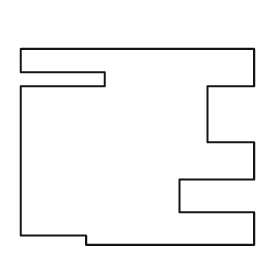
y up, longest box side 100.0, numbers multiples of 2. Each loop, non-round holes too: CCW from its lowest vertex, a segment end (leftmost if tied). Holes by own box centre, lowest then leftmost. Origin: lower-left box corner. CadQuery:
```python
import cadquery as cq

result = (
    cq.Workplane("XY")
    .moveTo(28.0, 0.0)
    .lineTo(100.0, 0.0)
    .lineTo(100.0, 14.0)
    .lineTo(68.0, 14.0)
    .lineTo(68.0, 28.0)
    .lineTo(100.0, 28.0)
    .lineTo(100.0, 44.0)
    .lineTo(80.0, 44.0)
    .lineTo(80.0, 68.0)
    .lineTo(100.0, 68.0)
    .lineTo(100.0, 84.0)
    .lineTo(0.0, 84.0)
    .lineTo(0.0, 74.0)
    .lineTo(36.0, 74.0)
    .lineTo(36.0, 68.0)
    .lineTo(0.0, 68.0)
    .lineTo(0.0, 4.0)
    .lineTo(28.0, 4.0)
    .close()
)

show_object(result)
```